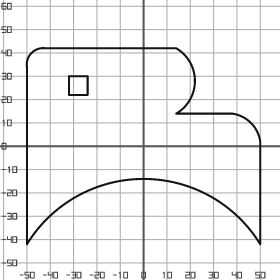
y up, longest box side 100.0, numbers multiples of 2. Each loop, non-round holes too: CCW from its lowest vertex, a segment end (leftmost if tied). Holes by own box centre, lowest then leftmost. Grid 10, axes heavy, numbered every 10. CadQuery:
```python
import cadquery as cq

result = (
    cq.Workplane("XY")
    .moveTo(-50.0, -42.0)
    .threePointArc((0.0, -14.0), (50.0, -42.0))
    .lineTo(50.0, 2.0)
    .threePointArc((46.0, 10.0), (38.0, 14.0))
    .lineTo(14.0, 14.0)
    .threePointArc((22.0, 28.0), (14.0, 42.0))
    .lineTo(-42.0, 42.0)
    .threePointArc((-48.0, 40.0), (-50.0, 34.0))
    .close()
    .moveTo(-32.0, 22.0)
    .lineTo(-24.0, 22.0)
    .lineTo(-24.0, 30.0)
    .lineTo(-32.0, 30.0)
    .close()
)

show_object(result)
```